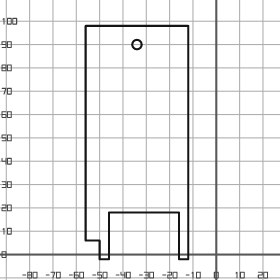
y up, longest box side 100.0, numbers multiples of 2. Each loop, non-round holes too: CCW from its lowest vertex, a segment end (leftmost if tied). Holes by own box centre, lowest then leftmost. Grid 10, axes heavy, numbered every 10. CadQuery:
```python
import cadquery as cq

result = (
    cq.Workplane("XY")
    .moveTo(-50.0, -2.0)
    .lineTo(-46.0, -2.0)
    .lineTo(-46.0, 18.0)
    .lineTo(-16.0, 18.0)
    .lineTo(-16.0, -2.0)
    .lineTo(-12.0, -2.0)
    .lineTo(-12.0, 98.0)
    .lineTo(-56.0, 98.0)
    .lineTo(-56.0, 6.0)
    .lineTo(-50.0, 6.0)
    .close()
    .moveTo(-34.0, 90.0)
    .circle(2.0)
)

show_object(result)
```